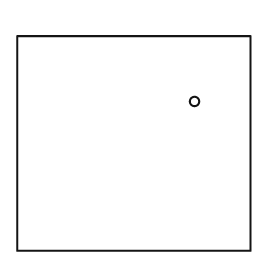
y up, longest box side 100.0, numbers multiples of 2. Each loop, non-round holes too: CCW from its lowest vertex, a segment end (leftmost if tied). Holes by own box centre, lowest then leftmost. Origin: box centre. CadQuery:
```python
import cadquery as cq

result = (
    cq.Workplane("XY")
    .moveTo(-50.0, -46.0)
    .lineTo(50.0, -46.0)
    .lineTo(50.0, 46.0)
    .lineTo(-50.0, 46.0)
    .close()
    .moveTo(26.0, 18.0)
    .circle(2.0)
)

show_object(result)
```